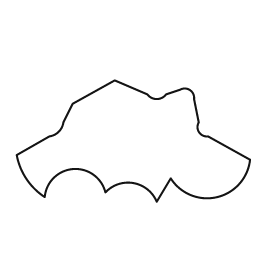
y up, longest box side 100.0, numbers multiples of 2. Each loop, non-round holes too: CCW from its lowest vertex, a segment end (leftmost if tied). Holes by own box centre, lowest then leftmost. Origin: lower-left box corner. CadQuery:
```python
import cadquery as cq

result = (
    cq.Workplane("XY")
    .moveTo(60.0, 0.0)
    .lineTo(66.0, 10.0)
    .threePointArc((86.0, 2.0), (100.0, 18.0))
    .lineTo(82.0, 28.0)
    .threePointArc((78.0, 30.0), (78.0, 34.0))
    .lineTo(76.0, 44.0)
    .threePointArc((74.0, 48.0), (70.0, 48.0))
    .lineTo(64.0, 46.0)
    .threePointArc((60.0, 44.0), (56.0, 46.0))
    .lineTo(42.0, 52.0)
    .lineTo(24.0, 42.0)
    .lineTo(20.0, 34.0)
    .threePointArc((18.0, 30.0), (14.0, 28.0))
    .lineTo(0.0, 20.0)
    .threePointArc((4.0, 10.0), (12.0, 2.0))
    .threePointArc((24.0, 14.0), (38.0, 4.0))
    .threePointArc((50.0, 8.0), (60.0, 0.0))
    .close()
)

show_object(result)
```